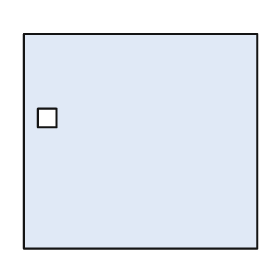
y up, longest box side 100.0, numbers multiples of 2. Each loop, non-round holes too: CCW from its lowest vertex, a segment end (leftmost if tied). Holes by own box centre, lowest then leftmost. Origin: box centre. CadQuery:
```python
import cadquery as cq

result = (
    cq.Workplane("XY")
    .moveTo(-50.0, -46.0)
    .lineTo(50.0, -46.0)
    .lineTo(50.0, 46.0)
    .lineTo(-50.0, 46.0)
    .close()
    .moveTo(-44.0, 6.0)
    .lineTo(-36.0, 6.0)
    .lineTo(-36.0, 14.0)
    .lineTo(-44.0, 14.0)
    .close()
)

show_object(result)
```